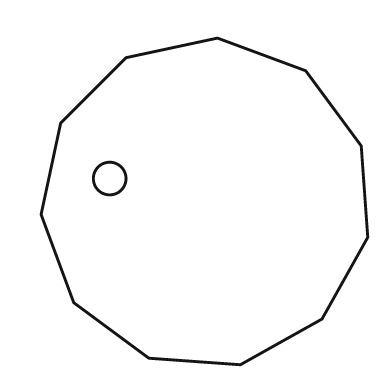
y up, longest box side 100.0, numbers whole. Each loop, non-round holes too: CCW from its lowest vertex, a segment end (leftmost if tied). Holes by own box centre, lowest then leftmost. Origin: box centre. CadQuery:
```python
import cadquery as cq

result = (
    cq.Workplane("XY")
    .moveTo(11.0, -50.0)
    .lineTo(36.0, -36.0)
    .lineTo(50.0, -11.0)
    .lineTo(48.0, 17.0)
    .lineTo(31.0, 40.0)
    .lineTo(4.0, 50.0)
    .lineTo(-24.0, 44.0)
    .lineTo(-44.0, 24.0)
    .lineTo(-50.0, -4.0)
    .lineTo(-40.0, -31.0)
    .lineTo(-17.0, -48.0)
    .close()
    .moveTo(-29.0, 7.0)
    .circle(5.0)
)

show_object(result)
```